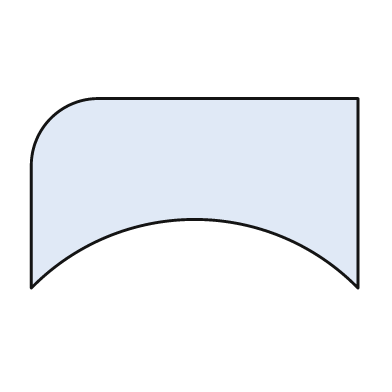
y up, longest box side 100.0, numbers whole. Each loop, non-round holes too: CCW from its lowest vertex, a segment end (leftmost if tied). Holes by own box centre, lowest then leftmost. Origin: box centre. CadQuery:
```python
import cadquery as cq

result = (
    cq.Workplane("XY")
    .moveTo(-50.0, -29.0)
    .threePointArc((0.0, -8.0), (50.0, -29.0))
    .lineTo(50.0, 29.0)
    .lineTo(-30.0, 29.0)
    .threePointArc((-44.0, 23.0), (-50.0, 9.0))
    .close()
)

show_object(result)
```